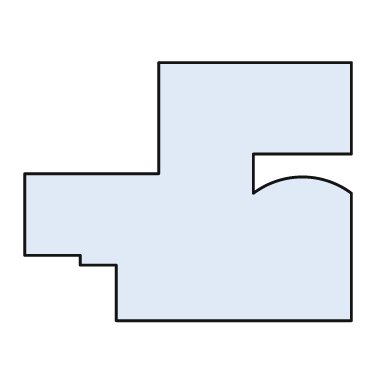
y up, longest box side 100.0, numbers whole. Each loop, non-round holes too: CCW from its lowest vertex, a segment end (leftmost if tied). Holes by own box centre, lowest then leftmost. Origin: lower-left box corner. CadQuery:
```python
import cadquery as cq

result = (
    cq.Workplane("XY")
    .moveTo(28.0, 0.0)
    .lineTo(100.0, 0.0)
    .lineTo(100.0, 39.0)
    .threePointArc((85.0, 44.0), (70.0, 39.0))
    .lineTo(70.0, 51.0)
    .lineTo(100.0, 51.0)
    .lineTo(100.0, 79.0)
    .lineTo(41.0, 79.0)
    .lineTo(41.0, 45.0)
    .lineTo(0.0, 45.0)
    .lineTo(0.0, 20.0)
    .lineTo(17.0, 20.0)
    .lineTo(17.0, 17.0)
    .lineTo(28.0, 17.0)
    .close()
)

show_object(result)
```